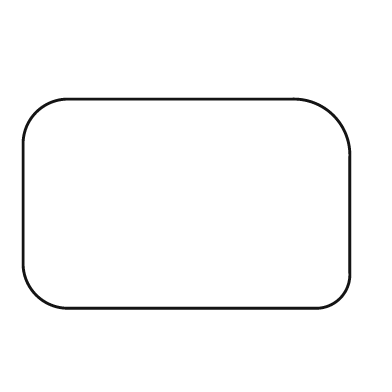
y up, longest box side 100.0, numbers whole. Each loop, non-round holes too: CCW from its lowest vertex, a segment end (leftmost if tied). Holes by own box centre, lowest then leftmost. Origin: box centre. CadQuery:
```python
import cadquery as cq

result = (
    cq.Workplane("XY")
    .moveTo(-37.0, -32.0)
    .lineTo(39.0, -32.0)
    .threePointArc((47.0, -29.0), (50.0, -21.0))
    .lineTo(50.0, 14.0)
    .threePointArc((45.0, 27.0), (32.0, 32.0))
    .lineTo(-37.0, 32.0)
    .threePointArc((-46.0, 28.0), (-50.0, 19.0))
    .lineTo(-50.0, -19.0)
    .threePointArc((-46.0, -28.0), (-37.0, -32.0))
    .close()
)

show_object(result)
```